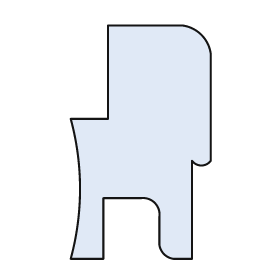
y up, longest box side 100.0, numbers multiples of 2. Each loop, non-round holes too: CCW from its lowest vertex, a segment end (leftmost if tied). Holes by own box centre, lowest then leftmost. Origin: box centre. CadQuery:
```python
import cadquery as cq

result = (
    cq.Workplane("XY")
    .moveTo(-30.0, -50.0)
    .lineTo(-16.0, -50.0)
    .lineTo(-16.0, -24.0)
    .lineTo(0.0, -24.0)
    .threePointArc((6.0, -26.0), (8.0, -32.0))
    .lineTo(8.0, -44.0)
    .threePointArc((10.0, -48.0), (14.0, -50.0))
    .lineTo(22.0, -50.0)
    .lineTo(22.0, -8.0)
    .threePointArc((26.0, -10.0), (30.0, -8.0))
    .lineTo(30.0, 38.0)
    .threePointArc((26.0, 46.0), (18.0, 50.0))
    .lineTo(-14.0, 50.0)
    .lineTo(-14.0, 10.0)
    .lineTo(-30.0, 10.0)
    .threePointArc((-26.0, -20.0), (-30.0, -50.0))
    .close()
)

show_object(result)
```